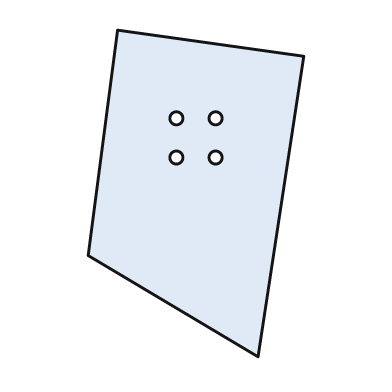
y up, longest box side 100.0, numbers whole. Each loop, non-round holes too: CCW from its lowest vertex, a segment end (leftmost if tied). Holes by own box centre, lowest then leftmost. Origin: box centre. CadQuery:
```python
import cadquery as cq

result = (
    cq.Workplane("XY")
    .moveTo(19.0, -50.0)
    .lineTo(33.0, 42.0)
    .lineTo(-24.0, 50.0)
    .lineTo(-33.0, -19.0)
    .close()
    .moveTo(-6.0, 11.0)
    .circle(2.0)
    .moveTo(6.0, 11.0)
    .circle(2.0)
    .moveTo(-6.0, 23.0)
    .circle(2.0)
    .moveTo(6.0, 23.0)
    .circle(2.0)
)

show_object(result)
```